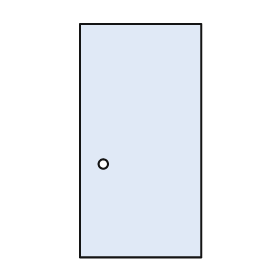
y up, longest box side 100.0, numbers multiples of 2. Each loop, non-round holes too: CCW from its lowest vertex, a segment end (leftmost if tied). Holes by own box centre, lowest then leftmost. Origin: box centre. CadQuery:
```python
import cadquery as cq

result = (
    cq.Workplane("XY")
    .moveTo(-26.0, -50.0)
    .lineTo(26.0, -50.0)
    .lineTo(26.0, 50.0)
    .lineTo(-26.0, 50.0)
    .close()
    .moveTo(-16.0, -10.0)
    .circle(2.0)
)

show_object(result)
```